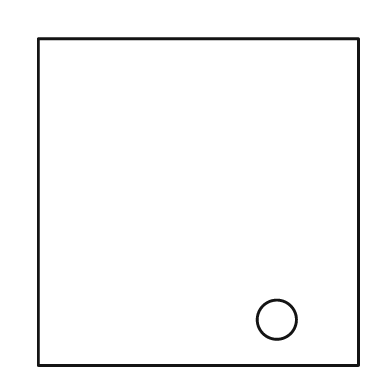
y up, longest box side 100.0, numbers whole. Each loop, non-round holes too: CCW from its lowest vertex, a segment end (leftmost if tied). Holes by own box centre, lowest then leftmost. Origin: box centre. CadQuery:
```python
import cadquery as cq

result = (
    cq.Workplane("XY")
    .moveTo(-49.0, -50.0)
    .lineTo(49.0, -50.0)
    .lineTo(49.0, 50.0)
    .lineTo(-49.0, 50.0)
    .close()
    .moveTo(24.0, -36.0)
    .circle(6.0)
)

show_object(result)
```